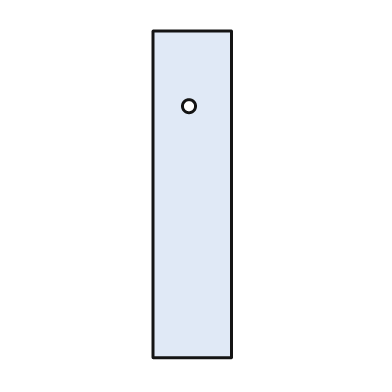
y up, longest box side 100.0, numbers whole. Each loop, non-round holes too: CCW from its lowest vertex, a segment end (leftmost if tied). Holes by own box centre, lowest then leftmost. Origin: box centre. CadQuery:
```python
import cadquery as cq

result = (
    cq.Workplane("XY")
    .moveTo(-12.0, -50.0)
    .lineTo(12.0, -50.0)
    .lineTo(12.0, 50.0)
    .lineTo(-12.0, 50.0)
    .close()
    .moveTo(-1.0, 27.0)
    .circle(2.0)
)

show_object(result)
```